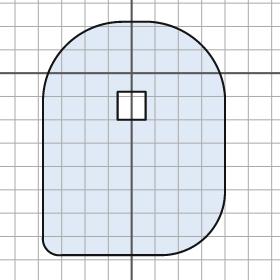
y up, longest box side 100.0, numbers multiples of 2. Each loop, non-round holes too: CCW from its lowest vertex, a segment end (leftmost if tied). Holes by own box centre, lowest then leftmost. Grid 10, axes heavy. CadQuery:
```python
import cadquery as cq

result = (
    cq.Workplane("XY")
    .moveTo(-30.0, -78.0)
    .lineTo(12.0, -78.0)
    .threePointArc((32.0, -70.0), (40.0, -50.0))
    .lineTo(40.0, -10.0)
    .threePointArc((30.0, 12.0), (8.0, 22.0))
    .lineTo(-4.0, 22.0)
    .threePointArc((-28.0, 12.0), (-38.0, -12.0))
    .lineTo(-38.0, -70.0)
    .threePointArc((-36.0, -76.0), (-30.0, -78.0))
    .close()
    .moveTo(-6.0, -20.0)
    .lineTo(6.0, -20.0)
    .lineTo(6.0, -8.0)
    .lineTo(-6.0, -8.0)
    .close()
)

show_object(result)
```